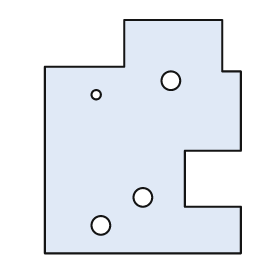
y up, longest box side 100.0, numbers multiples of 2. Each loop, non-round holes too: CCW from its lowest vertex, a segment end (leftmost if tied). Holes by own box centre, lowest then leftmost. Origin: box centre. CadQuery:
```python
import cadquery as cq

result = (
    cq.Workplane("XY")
    .moveTo(-42.0, -50.0)
    .lineTo(42.0, -50.0)
    .lineTo(42.0, -30.0)
    .lineTo(18.0, -30.0)
    .lineTo(18.0, -6.0)
    .lineTo(42.0, -6.0)
    .lineTo(42.0, 28.0)
    .lineTo(34.0, 28.0)
    .lineTo(34.0, 50.0)
    .lineTo(-8.0, 50.0)
    .lineTo(-8.0, 30.0)
    .lineTo(-42.0, 30.0)
    .close()
    .moveTo(-18.0, -38.0)
    .circle(4.0)
    .moveTo(0.0, -26.0)
    .circle(4.0)
    .moveTo(-20.0, 18.0)
    .circle(2.0)
    .moveTo(12.0, 24.0)
    .circle(4.0)
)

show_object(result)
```